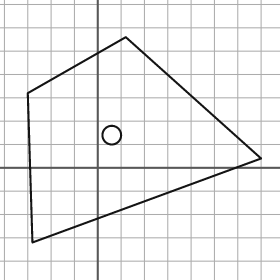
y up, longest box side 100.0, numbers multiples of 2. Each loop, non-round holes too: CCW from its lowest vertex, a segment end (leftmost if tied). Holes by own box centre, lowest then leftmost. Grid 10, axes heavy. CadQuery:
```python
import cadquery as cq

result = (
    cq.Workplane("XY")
    .moveTo(-28.0, -32.0)
    .lineTo(70.0, 4.0)
    .lineTo(12.0, 56.0)
    .lineTo(-30.0, 32.0)
    .close()
    .moveTo(6.0, 14.0)
    .circle(4.0)
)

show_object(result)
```